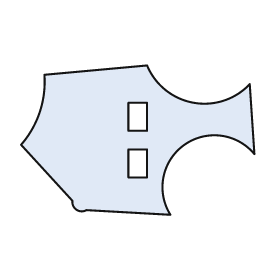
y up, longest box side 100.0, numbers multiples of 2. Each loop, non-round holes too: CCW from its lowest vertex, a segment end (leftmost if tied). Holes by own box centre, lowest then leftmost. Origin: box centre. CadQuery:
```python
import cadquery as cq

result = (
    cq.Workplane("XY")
    .moveTo(14.0, -32.0)
    .threePointArc((20.0, -2.0), (50.0, -6.0))
    .lineTo(48.0, 24.0)
    .threePointArc((24.0, 16.0), (4.0, 32.0))
    .lineTo(-40.0, 28.0)
    .threePointArc((-42.0, 12.0), (-50.0, -2.0))
    .lineTo(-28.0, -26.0)
    .threePointArc((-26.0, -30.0), (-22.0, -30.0))
    .close()
    .moveTo(-4.0, -16.0)
    .lineTo(4.0, -16.0)
    .lineTo(4.0, -4.0)
    .lineTo(-4.0, -4.0)
    .close()
    .moveTo(-4.0, 4.0)
    .lineTo(4.0, 4.0)
    .lineTo(4.0, 16.0)
    .lineTo(-4.0, 16.0)
    .close()
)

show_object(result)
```